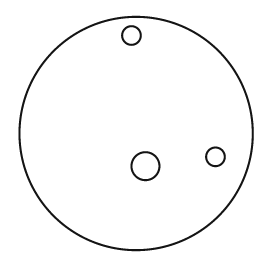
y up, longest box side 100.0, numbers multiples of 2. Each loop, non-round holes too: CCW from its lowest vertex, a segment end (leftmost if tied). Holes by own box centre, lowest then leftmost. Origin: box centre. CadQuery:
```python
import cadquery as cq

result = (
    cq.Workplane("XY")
    .moveTo(0.0, 0.0)
    .circle(50.0)
    .moveTo(4.0, -14.0)
    .circle(6.0)
    .moveTo(34.0, -10.0)
    .circle(4.0)
    .moveTo(-2.0, 42.0)
    .circle(4.0)
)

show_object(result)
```